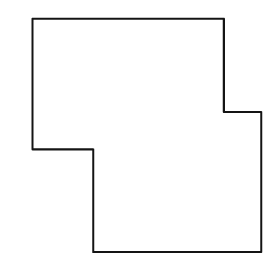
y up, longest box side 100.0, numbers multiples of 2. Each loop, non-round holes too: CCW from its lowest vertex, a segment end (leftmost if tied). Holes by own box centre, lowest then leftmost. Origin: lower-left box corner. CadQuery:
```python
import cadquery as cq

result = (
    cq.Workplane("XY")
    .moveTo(26.0, 0.0)
    .lineTo(98.0, 0.0)
    .lineTo(98.0, 60.0)
    .lineTo(82.0, 60.0)
    .lineTo(82.0, 100.0)
    .lineTo(0.0, 100.0)
    .lineTo(0.0, 44.0)
    .lineTo(26.0, 44.0)
    .close()
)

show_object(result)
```